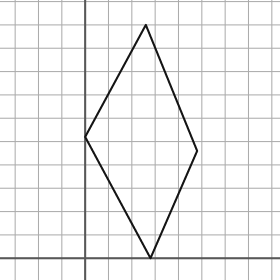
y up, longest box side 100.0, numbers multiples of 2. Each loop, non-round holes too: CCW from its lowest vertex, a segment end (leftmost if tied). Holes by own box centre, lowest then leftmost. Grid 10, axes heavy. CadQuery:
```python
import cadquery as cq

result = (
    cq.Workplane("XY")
    .moveTo(28.0, 0.0)
    .lineTo(48.0, 46.0)
    .lineTo(26.0, 100.0)
    .lineTo(0.0, 52.0)
    .close()
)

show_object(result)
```